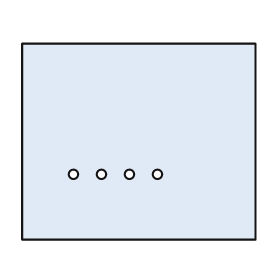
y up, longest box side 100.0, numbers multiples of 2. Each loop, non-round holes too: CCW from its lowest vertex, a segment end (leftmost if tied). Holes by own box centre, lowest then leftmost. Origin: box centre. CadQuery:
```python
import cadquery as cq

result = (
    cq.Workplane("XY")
    .moveTo(-50.0, -42.0)
    .lineTo(50.0, -42.0)
    .lineTo(50.0, 42.0)
    .lineTo(-50.0, 42.0)
    .close()
    .moveTo(-28.0, -14.0)
    .circle(2.0)
    .moveTo(-16.0, -14.0)
    .circle(2.0)
    .moveTo(-4.0, -14.0)
    .circle(2.0)
    .moveTo(8.0, -14.0)
    .circle(2.0)
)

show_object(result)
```